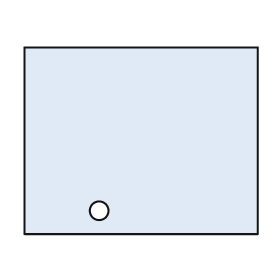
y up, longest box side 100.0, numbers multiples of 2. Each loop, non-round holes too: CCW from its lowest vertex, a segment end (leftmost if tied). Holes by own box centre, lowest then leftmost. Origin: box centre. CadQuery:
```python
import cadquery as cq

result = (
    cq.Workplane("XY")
    .moveTo(-50.0, -40.0)
    .lineTo(50.0, -40.0)
    .lineTo(50.0, 40.0)
    .lineTo(-50.0, 40.0)
    .close()
    .moveTo(-18.0, -30.0)
    .circle(4.0)
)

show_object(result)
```